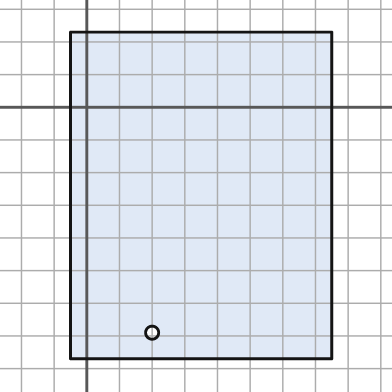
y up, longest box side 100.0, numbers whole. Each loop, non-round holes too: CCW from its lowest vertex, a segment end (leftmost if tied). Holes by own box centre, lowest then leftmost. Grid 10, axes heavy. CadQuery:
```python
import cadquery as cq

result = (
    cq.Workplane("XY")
    .moveTo(-5.0, -77.0)
    .lineTo(75.0, -77.0)
    .lineTo(75.0, 23.0)
    .lineTo(-5.0, 23.0)
    .close()
    .moveTo(20.0, -69.0)
    .circle(2.0)
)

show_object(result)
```